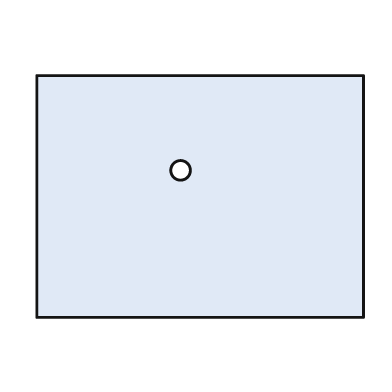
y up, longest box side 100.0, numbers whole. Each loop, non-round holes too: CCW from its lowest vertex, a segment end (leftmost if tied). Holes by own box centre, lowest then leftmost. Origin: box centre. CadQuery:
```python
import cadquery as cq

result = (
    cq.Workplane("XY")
    .moveTo(-50.0, -37.0)
    .lineTo(50.0, -37.0)
    .lineTo(50.0, 37.0)
    .lineTo(-50.0, 37.0)
    .close()
    .moveTo(-6.0, 8.0)
    .circle(3.0)
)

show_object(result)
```